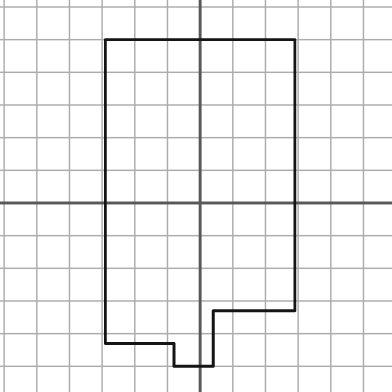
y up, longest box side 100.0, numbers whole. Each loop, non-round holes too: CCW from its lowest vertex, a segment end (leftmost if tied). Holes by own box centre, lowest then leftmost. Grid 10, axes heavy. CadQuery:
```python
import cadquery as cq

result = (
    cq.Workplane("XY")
    .moveTo(-8.0, -50.0)
    .lineTo(4.0, -50.0)
    .lineTo(4.0, -33.0)
    .lineTo(29.0, -33.0)
    .lineTo(29.0, 50.0)
    .lineTo(-29.0, 50.0)
    .lineTo(-29.0, -43.0)
    .lineTo(-8.0, -43.0)
    .close()
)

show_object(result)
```